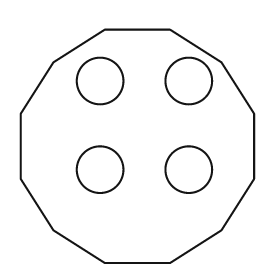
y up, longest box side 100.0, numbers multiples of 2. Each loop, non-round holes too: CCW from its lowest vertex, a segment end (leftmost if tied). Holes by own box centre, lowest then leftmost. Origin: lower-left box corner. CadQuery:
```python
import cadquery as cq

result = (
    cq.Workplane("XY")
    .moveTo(36.0, 0.0)
    .lineTo(64.0, 0.0)
    .lineTo(86.0, 14.0)
    .lineTo(100.0, 36.0)
    .lineTo(100.0, 64.0)
    .lineTo(86.0, 86.0)
    .lineTo(64.0, 100.0)
    .lineTo(36.0, 100.0)
    .lineTo(14.0, 86.0)
    .lineTo(0.0, 64.0)
    .lineTo(0.0, 36.0)
    .lineTo(14.0, 14.0)
    .close()
    .moveTo(34.0, 40.0)
    .circle(10.0)
    .moveTo(72.0, 40.0)
    .circle(10.0)
    .moveTo(34.0, 78.0)
    .circle(10.0)
    .moveTo(72.0, 78.0)
    .circle(10.0)
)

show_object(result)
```